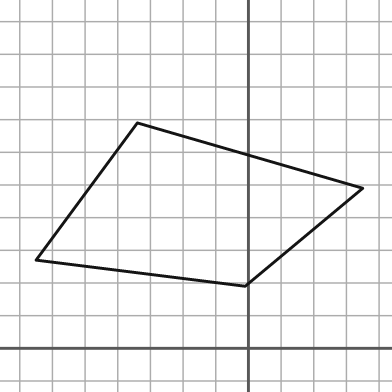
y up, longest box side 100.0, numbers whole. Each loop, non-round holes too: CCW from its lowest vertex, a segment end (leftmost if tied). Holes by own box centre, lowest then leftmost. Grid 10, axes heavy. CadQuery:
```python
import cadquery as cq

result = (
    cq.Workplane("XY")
    .moveTo(-1.0, 19.0)
    .lineTo(35.0, 49.0)
    .lineTo(-34.0, 69.0)
    .lineTo(-65.0, 27.0)
    .close()
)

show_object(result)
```